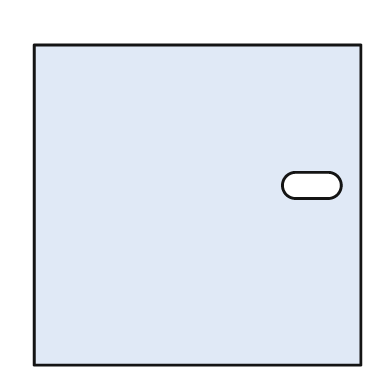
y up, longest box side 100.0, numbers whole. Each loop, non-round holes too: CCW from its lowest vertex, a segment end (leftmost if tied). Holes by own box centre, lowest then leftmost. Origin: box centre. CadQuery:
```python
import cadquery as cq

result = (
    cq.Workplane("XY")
    .moveTo(-50.0, -49.0)
    .lineTo(50.0, -49.0)
    .lineTo(50.0, 49.0)
    .lineTo(-50.0, 49.0)
    .close()
    .moveTo(30.0, 2.0)
    .lineTo(40.0, 2.0)
    .threePointArc((44.0, 6.0), (40.0, 10.0))
    .lineTo(30.0, 10.0)
    .threePointArc((26.0, 6.0), (30.0, 2.0))
    .close()
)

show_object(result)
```